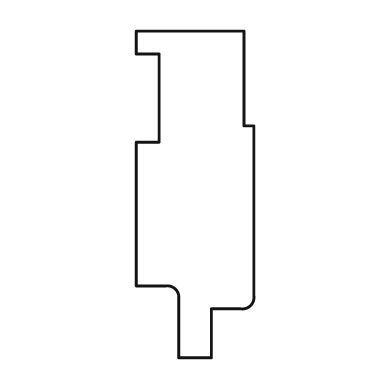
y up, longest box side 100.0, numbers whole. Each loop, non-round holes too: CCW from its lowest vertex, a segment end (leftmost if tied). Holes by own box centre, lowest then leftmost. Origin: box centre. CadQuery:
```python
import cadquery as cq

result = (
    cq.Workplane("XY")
    .moveTo(-5.0, -50.0)
    .lineTo(5.0, -50.0)
    .lineTo(5.0, -35.0)
    .lineTo(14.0, -35.0)
    .threePointArc((17.0, -34.0), (18.0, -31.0))
    .lineTo(18.0, 21.0)
    .lineTo(15.0, 21.0)
    .lineTo(15.0, 50.0)
    .lineTo(-18.0, 50.0)
    .lineTo(-18.0, 43.0)
    .lineTo(-11.0, 43.0)
    .lineTo(-11.0, 16.0)
    .lineTo(-18.0, 16.0)
    .lineTo(-18.0, -28.0)
    .lineTo(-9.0, -28.0)
    .threePointArc((-6.0, -29.0), (-5.0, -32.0))
    .close()
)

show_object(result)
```